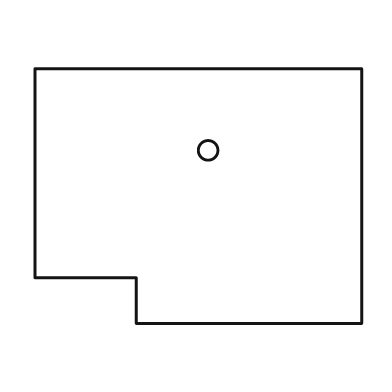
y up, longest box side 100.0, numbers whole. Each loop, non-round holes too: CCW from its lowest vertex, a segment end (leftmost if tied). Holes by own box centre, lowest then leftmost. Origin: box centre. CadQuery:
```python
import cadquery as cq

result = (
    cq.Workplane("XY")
    .moveTo(-19.0, -39.0)
    .lineTo(50.0, -39.0)
    .lineTo(50.0, 39.0)
    .lineTo(-50.0, 39.0)
    .lineTo(-50.0, -25.0)
    .lineTo(-19.0, -25.0)
    .close()
    .moveTo(3.0, 14.0)
    .circle(3.0)
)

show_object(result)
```